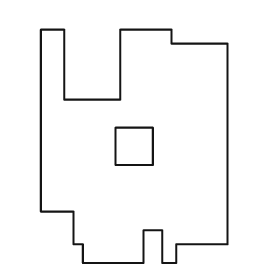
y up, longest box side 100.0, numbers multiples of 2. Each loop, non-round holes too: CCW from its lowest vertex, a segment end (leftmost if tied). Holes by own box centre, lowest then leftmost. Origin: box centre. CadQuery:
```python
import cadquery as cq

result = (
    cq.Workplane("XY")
    .moveTo(-22.0, -50.0)
    .lineTo(4.0, -50.0)
    .lineTo(4.0, -36.0)
    .lineTo(12.0, -36.0)
    .lineTo(12.0, -50.0)
    .lineTo(18.0, -50.0)
    .lineTo(18.0, -42.0)
    .lineTo(40.0, -42.0)
    .lineTo(40.0, 44.0)
    .lineTo(16.0, 44.0)
    .lineTo(16.0, 50.0)
    .lineTo(-6.0, 50.0)
    .lineTo(-6.0, 20.0)
    .lineTo(-30.0, 20.0)
    .lineTo(-30.0, 50.0)
    .lineTo(-40.0, 50.0)
    .lineTo(-40.0, -28.0)
    .lineTo(-26.0, -28.0)
    .lineTo(-26.0, -42.0)
    .lineTo(-22.0, -42.0)
    .close()
    .moveTo(-8.0, -8.0)
    .lineTo(8.0, -8.0)
    .lineTo(8.0, 8.0)
    .lineTo(-8.0, 8.0)
    .close()
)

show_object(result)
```